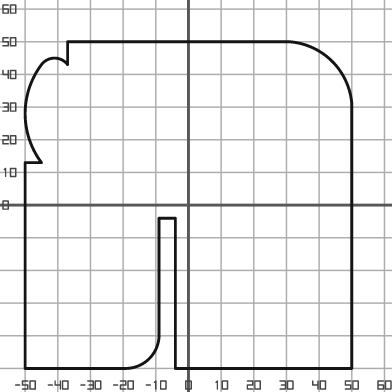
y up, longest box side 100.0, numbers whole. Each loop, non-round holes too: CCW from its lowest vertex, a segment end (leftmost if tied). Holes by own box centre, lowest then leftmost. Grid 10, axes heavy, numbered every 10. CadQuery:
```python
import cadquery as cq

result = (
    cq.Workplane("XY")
    .moveTo(-50.0, -50.0)
    .lineTo(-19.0, -50.0)
    .threePointArc((-12.0, -47.0), (-9.0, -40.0))
    .lineTo(-9.0, -4.0)
    .lineTo(-4.0, -4.0)
    .lineTo(-4.0, -50.0)
    .lineTo(50.0, -50.0)
    .lineTo(50.0, 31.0)
    .threePointArc((44.0, 44.0), (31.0, 50.0))
    .lineTo(-37.0, 50.0)
    .lineTo(-37.0, 43.0)
    .threePointArc((-41.0, 45.0), (-45.0, 43.0))
    .threePointArc((-50.0, 28.0), (-45.0, 13.0))
    .lineTo(-50.0, 13.0)
    .close()
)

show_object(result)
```